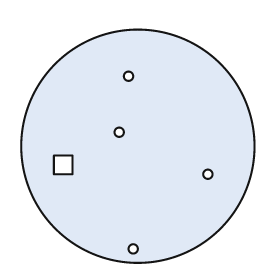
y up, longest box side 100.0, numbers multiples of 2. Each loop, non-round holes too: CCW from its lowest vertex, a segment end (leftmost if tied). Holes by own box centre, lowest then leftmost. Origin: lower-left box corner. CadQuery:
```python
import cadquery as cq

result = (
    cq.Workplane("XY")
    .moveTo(50.0, 50.0)
    .circle(50.0)
    .moveTo(48.0, 6.0)
    .circle(2.0)
    .moveTo(80.0, 38.0)
    .circle(2.0)
    .moveTo(14.0, 38.0)
    .lineTo(22.0, 38.0)
    .lineTo(22.0, 46.0)
    .lineTo(14.0, 46.0)
    .close()
    .moveTo(42.0, 56.0)
    .circle(2.0)
    .moveTo(46.0, 80.0)
    .circle(2.0)
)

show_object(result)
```